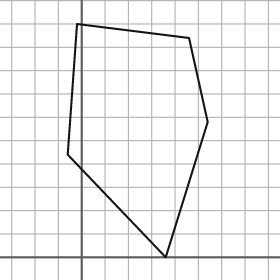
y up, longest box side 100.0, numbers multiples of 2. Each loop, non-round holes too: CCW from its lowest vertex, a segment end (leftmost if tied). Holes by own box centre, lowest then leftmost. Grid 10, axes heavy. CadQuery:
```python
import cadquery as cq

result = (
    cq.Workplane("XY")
    .moveTo(36.0, 0.0)
    .lineTo(54.0, 58.0)
    .lineTo(46.0, 94.0)
    .lineTo(-2.0, 100.0)
    .lineTo(-6.0, 44.0)
    .close()
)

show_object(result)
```